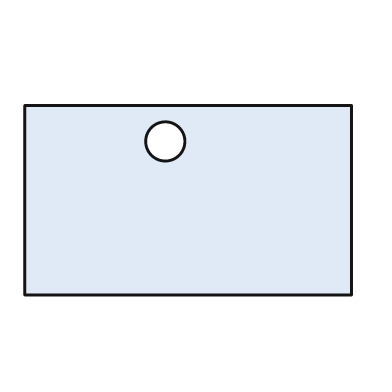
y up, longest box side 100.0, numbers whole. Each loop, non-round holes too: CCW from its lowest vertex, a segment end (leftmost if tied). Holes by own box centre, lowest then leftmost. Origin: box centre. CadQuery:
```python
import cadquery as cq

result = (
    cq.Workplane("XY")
    .moveTo(-50.0, -29.0)
    .lineTo(50.0, -29.0)
    .lineTo(50.0, 29.0)
    .lineTo(-50.0, 29.0)
    .close()
    .moveTo(-7.0, 18.0)
    .circle(6.0)
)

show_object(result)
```